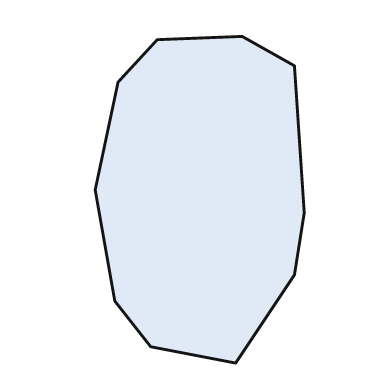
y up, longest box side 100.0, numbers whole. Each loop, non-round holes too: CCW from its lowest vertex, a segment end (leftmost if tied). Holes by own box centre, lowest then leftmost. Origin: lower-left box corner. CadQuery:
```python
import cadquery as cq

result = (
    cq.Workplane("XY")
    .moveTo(43.0, 0.0)
    .lineTo(61.0, 27.0)
    .lineTo(64.0, 46.0)
    .lineTo(61.0, 91.0)
    .lineTo(45.0, 100.0)
    .lineTo(19.0, 99.0)
    .lineTo(7.0, 86.0)
    .lineTo(0.0, 53.0)
    .lineTo(6.0, 19.0)
    .lineTo(17.0, 5.0)
    .close()
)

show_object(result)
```